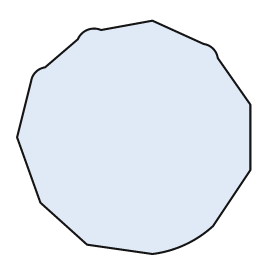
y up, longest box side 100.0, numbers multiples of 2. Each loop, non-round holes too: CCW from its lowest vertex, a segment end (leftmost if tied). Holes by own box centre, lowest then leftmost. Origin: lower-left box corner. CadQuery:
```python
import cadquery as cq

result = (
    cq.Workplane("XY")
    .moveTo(58.0, 0.0)
    .threePointArc((72.0, 4.0), (84.0, 12.0))
    .lineTo(100.0, 36.0)
    .lineTo(100.0, 64.0)
    .lineTo(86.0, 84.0)
    .threePointArc((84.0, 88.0), (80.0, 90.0))
    .lineTo(58.0, 100.0)
    .lineTo(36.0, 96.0)
    .threePointArc((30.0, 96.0), (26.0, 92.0))
    .lineTo(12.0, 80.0)
    .threePointArc((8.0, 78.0), (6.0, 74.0))
    .lineTo(0.0, 50.0)
    .lineTo(10.0, 22.0)
    .lineTo(30.0, 4.0)
    .close()
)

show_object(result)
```